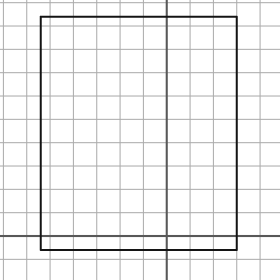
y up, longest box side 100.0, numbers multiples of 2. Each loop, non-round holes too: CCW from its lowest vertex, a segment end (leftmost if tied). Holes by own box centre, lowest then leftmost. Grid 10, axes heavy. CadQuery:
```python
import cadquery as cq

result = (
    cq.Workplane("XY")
    .moveTo(-54.0, -6.0)
    .lineTo(30.0, -6.0)
    .lineTo(30.0, 94.0)
    .lineTo(-54.0, 94.0)
    .close()
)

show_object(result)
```